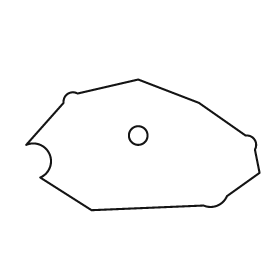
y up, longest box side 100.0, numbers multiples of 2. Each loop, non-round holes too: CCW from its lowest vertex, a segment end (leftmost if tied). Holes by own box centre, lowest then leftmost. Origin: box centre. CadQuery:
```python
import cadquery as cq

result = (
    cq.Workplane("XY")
    .moveTo(-22.0, -28.0)
    .lineTo(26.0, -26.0)
    .threePointArc((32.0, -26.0), (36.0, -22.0))
    .lineTo(50.0, -12.0)
    .lineTo(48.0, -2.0)
    .threePointArc((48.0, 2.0), (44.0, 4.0))
    .lineTo(24.0, 18.0)
    .lineTo(-2.0, 28.0)
    .lineTo(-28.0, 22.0)
    .threePointArc((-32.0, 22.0), (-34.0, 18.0))
    .lineTo(-50.0, 0.0)
    .threePointArc((-40.0, -4.0), (-44.0, -14.0))
    .close()
    .moveTo(-2.0, 4.0)
    .circle(4.0)
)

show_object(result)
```